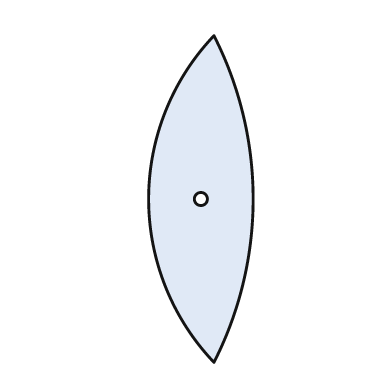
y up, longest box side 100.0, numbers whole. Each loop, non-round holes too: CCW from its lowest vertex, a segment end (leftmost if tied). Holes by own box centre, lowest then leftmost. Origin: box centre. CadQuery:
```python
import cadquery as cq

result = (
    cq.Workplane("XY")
    .moveTo(4.0, -50.0)
    .threePointArc((16.0, 0.0), (4.0, 50.0))
    .threePointArc((-16.0, 0.0), (4.0, -50.0))
    .close()
    .moveTo(0.0, 0.0)
    .circle(2.0)
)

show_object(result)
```